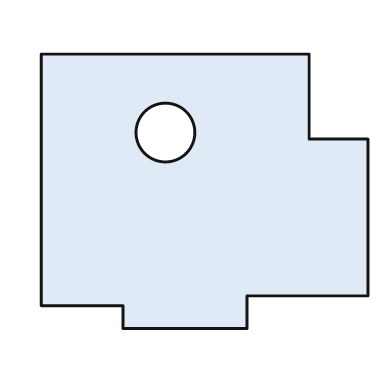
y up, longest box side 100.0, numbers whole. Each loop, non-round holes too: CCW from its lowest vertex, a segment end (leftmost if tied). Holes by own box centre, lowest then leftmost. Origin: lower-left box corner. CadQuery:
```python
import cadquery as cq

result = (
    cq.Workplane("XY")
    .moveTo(25.0, 0.0)
    .lineTo(63.0, 0.0)
    .lineTo(63.0, 10.0)
    .lineTo(100.0, 10.0)
    .lineTo(100.0, 58.0)
    .lineTo(82.0, 58.0)
    .lineTo(82.0, 84.0)
    .lineTo(0.0, 84.0)
    .lineTo(0.0, 7.0)
    .lineTo(25.0, 7.0)
    .close()
    .moveTo(38.0, 60.0)
    .circle(9.0)
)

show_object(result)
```